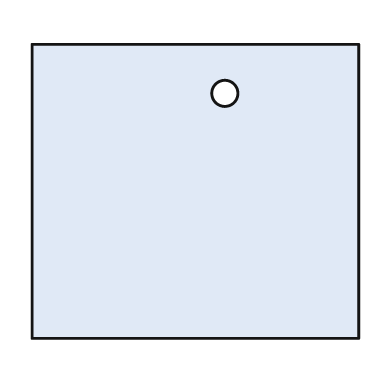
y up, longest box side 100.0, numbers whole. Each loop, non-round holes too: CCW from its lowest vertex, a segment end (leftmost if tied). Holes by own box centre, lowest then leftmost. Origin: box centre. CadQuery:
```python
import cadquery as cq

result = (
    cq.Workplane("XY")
    .moveTo(-50.0, -45.0)
    .lineTo(50.0, -45.0)
    .lineTo(50.0, 45.0)
    .lineTo(-50.0, 45.0)
    .close()
    .moveTo(9.0, 30.0)
    .circle(4.0)
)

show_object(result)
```